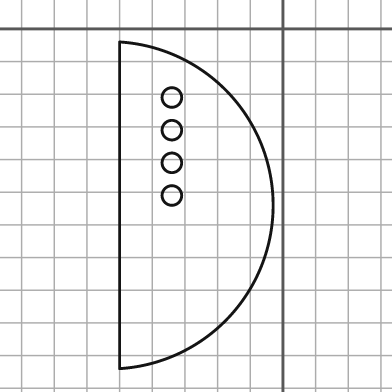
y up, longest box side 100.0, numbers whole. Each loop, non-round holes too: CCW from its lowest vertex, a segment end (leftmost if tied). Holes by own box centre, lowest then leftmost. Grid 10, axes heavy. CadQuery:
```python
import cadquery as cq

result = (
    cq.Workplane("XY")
    .moveTo(-50.0, -104.0)
    .threePointArc((-3.0, -54.0), (-50.0, -4.0))
    .close()
    .moveTo(-34.0, -51.0)
    .circle(3.0)
    .moveTo(-34.0, -41.0)
    .circle(3.0)
    .moveTo(-34.0, -31.0)
    .circle(3.0)
    .moveTo(-34.0, -21.0)
    .circle(3.0)
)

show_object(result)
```